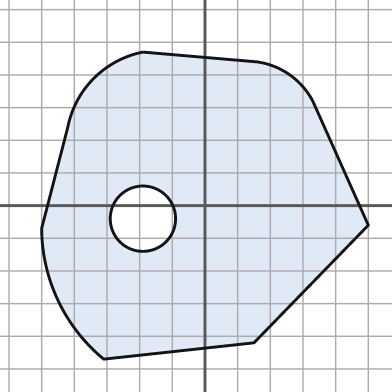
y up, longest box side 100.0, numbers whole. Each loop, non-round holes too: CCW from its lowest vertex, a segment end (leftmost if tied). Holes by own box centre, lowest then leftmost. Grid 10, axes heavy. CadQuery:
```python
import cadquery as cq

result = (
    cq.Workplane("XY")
    .moveTo(-31.0, -47.0)
    .lineTo(15.0, -42.0)
    .lineTo(50.0, -6.0)
    .lineTo(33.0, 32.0)
    .threePointArc((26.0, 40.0), (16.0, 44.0))
    .lineTo(-19.0, 47.0)
    .threePointArc((-34.0, 39.0), (-42.0, 24.0))
    .lineTo(-50.0, -7.0)
    .threePointArc((-45.0, -29.0), (-31.0, -47.0))
    .close()
    .moveTo(-19.0, -4.0)
    .circle(10.0)
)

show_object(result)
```